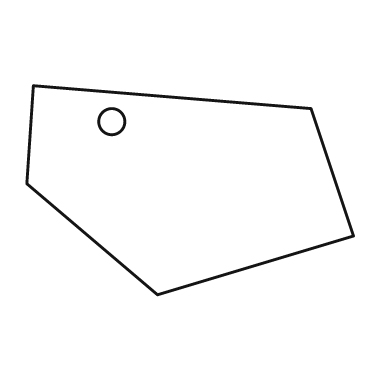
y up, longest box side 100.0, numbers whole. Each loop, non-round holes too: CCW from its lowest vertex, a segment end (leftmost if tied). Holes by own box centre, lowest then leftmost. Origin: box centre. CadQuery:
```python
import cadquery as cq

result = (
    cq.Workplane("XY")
    .moveTo(-10.0, -32.0)
    .lineTo(50.0, -14.0)
    .lineTo(37.0, 25.0)
    .lineTo(-48.0, 32.0)
    .lineTo(-50.0, 2.0)
    .close()
    .moveTo(-24.0, 21.0)
    .circle(4.0)
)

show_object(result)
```